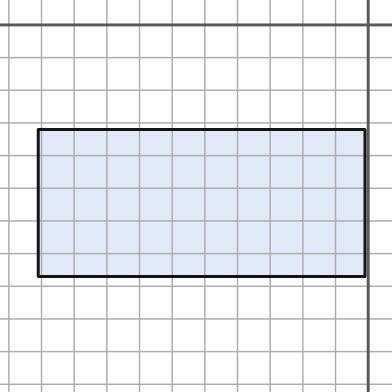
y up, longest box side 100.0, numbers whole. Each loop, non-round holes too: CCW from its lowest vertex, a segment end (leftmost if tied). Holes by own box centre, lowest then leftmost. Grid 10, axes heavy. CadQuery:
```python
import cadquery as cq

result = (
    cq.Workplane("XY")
    .moveTo(-101.0, -77.0)
    .lineTo(-1.0, -77.0)
    .lineTo(-1.0, -32.0)
    .lineTo(-101.0, -32.0)
    .close()
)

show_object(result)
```